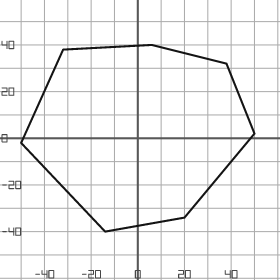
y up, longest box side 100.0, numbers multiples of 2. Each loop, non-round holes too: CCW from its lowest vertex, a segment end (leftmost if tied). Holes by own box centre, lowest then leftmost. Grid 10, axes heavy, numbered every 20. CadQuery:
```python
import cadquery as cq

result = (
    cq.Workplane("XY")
    .moveTo(-14.0, -40.0)
    .lineTo(20.0, -34.0)
    .lineTo(50.0, 2.0)
    .lineTo(38.0, 32.0)
    .lineTo(6.0, 40.0)
    .lineTo(-32.0, 38.0)
    .lineTo(-50.0, -2.0)
    .close()
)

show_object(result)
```